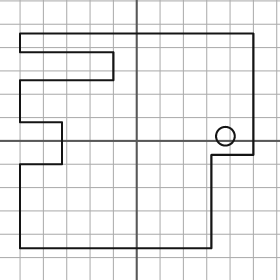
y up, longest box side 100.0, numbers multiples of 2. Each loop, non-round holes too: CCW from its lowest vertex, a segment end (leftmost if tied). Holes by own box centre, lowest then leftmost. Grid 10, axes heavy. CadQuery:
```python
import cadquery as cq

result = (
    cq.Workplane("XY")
    .moveTo(-50.0, -46.0)
    .lineTo(32.0, -46.0)
    .lineTo(32.0, -6.0)
    .lineTo(50.0, -6.0)
    .lineTo(50.0, 46.0)
    .lineTo(-50.0, 46.0)
    .lineTo(-50.0, 38.0)
    .lineTo(-10.0, 38.0)
    .lineTo(-10.0, 26.0)
    .lineTo(-50.0, 26.0)
    .lineTo(-50.0, 8.0)
    .lineTo(-32.0, 8.0)
    .lineTo(-32.0, -10.0)
    .lineTo(-50.0, -10.0)
    .close()
    .moveTo(38.0, 2.0)
    .circle(4.0)
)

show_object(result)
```